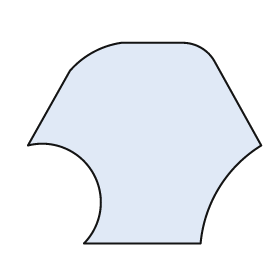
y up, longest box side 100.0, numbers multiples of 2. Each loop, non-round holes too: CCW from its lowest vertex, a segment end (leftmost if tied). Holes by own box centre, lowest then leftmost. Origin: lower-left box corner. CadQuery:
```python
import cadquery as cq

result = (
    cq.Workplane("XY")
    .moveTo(24.0, 0.0)
    .lineTo(74.0, 0.0)
    .threePointArc((82.0, 24.0), (100.0, 42.0))
    .lineTo(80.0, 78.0)
    .threePointArc((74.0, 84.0), (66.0, 86.0))
    .lineTo(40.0, 86.0)
    .threePointArc((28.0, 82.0), (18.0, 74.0))
    .lineTo(0.0, 42.0)
    .threePointArc((28.0, 30.0), (24.0, 0.0))
    .close()
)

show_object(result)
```